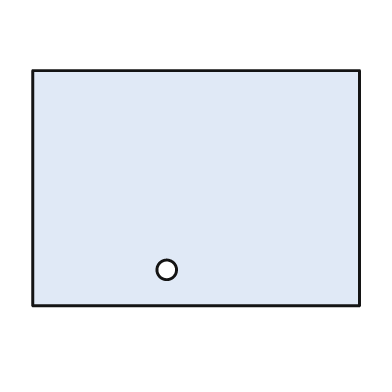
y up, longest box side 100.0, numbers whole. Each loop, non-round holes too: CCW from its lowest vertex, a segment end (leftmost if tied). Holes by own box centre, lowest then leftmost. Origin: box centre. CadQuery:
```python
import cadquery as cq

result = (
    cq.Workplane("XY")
    .moveTo(-50.0, -36.0)
    .lineTo(50.0, -36.0)
    .lineTo(50.0, 36.0)
    .lineTo(-50.0, 36.0)
    .close()
    .moveTo(-9.0, -25.0)
    .circle(3.0)
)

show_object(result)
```